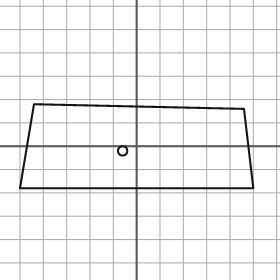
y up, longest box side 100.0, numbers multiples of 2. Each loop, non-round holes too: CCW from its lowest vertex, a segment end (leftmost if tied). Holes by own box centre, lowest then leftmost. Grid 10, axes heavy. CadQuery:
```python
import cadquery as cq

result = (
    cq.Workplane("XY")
    .moveTo(-50.0, -18.0)
    .lineTo(50.0, -18.0)
    .lineTo(46.0, 16.0)
    .lineTo(-44.0, 18.0)
    .close()
    .moveTo(-6.0, -2.0)
    .circle(2.0)
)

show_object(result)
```